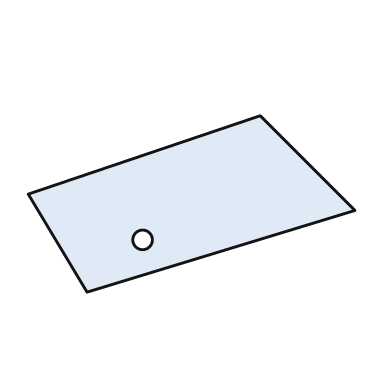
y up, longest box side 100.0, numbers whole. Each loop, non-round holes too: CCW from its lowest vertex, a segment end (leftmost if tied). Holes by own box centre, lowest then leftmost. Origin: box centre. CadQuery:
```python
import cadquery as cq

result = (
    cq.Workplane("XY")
    .moveTo(-32.0, -27.0)
    .lineTo(50.0, -2.0)
    .lineTo(21.0, 27.0)
    .lineTo(-50.0, 3.0)
    .close()
    .moveTo(-15.0, -11.0)
    .circle(3.0)
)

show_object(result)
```